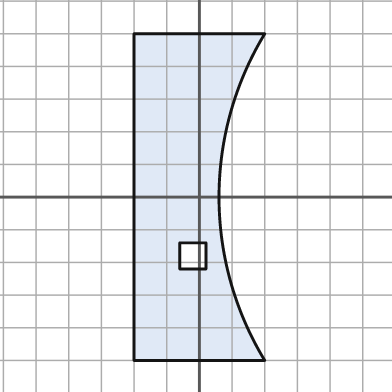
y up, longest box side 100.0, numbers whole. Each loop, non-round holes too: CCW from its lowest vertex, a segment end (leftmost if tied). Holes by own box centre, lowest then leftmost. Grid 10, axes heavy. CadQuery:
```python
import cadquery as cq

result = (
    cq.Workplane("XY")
    .moveTo(-20.0, -50.0)
    .lineTo(20.0, -50.0)
    .threePointArc((6.0, 0.0), (20.0, 50.0))
    .lineTo(-20.0, 50.0)
    .close()
    .moveTo(-6.0, -22.0)
    .lineTo(2.0, -22.0)
    .lineTo(2.0, -14.0)
    .lineTo(-6.0, -14.0)
    .close()
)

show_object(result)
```